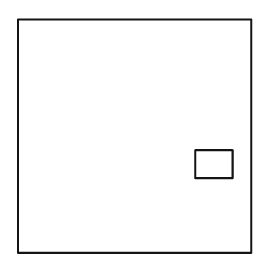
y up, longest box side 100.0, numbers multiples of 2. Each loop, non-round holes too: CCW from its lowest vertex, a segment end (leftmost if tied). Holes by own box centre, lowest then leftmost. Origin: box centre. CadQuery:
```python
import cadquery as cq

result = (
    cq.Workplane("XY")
    .moveTo(-50.0, -50.0)
    .lineTo(50.0, -50.0)
    .lineTo(50.0, 50.0)
    .lineTo(-50.0, 50.0)
    .close()
    .moveTo(26.0, -18.0)
    .lineTo(42.0, -18.0)
    .lineTo(42.0, -6.0)
    .lineTo(26.0, -6.0)
    .close()
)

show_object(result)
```